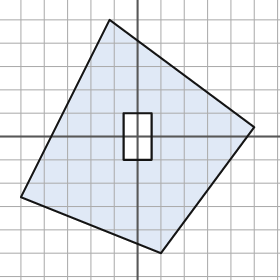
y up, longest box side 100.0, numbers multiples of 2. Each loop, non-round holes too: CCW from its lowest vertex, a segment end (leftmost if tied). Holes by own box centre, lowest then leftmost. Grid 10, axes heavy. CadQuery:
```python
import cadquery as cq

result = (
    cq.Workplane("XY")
    .moveTo(10.0, -50.0)
    .lineTo(50.0, 4.0)
    .lineTo(-12.0, 50.0)
    .lineTo(-50.0, -26.0)
    .close()
    .moveTo(-6.0, -10.0)
    .lineTo(6.0, -10.0)
    .lineTo(6.0, 10.0)
    .lineTo(-6.0, 10.0)
    .close()
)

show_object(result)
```